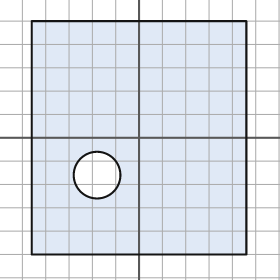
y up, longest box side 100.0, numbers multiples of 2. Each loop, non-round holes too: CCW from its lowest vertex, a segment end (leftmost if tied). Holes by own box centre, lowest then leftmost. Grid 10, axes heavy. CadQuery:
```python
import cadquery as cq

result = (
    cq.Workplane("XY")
    .moveTo(-46.0, -50.0)
    .lineTo(46.0, -50.0)
    .lineTo(46.0, 50.0)
    .lineTo(-46.0, 50.0)
    .close()
    .moveTo(-18.0, -16.0)
    .circle(10.0)
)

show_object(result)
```